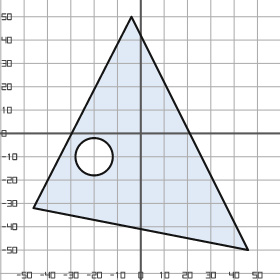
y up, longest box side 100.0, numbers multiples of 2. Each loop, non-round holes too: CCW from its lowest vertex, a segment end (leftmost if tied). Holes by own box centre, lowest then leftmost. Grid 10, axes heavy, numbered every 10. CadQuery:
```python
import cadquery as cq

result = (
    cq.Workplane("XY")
    .moveTo(46.0, -50.0)
    .lineTo(-4.0, 50.0)
    .lineTo(-46.0, -32.0)
    .close()
    .moveTo(-20.0, -10.0)
    .circle(8.0)
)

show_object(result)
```